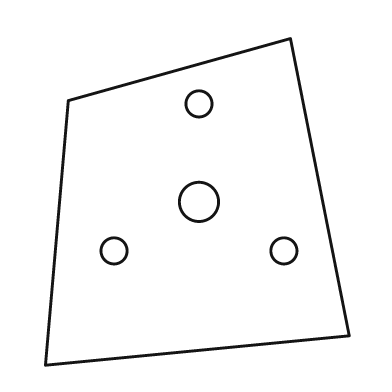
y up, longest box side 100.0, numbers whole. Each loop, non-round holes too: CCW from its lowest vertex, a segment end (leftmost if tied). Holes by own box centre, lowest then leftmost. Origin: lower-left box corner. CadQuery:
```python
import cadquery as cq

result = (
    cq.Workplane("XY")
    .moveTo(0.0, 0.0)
    .lineTo(93.0, 9.0)
    .lineTo(75.0, 100.0)
    .lineTo(7.0, 81.0)
    .close()
    .moveTo(21.0, 35.0)
    .circle(4.0)
    .moveTo(73.0, 35.0)
    .circle(4.0)
    .moveTo(47.0, 50.0)
    .circle(6.0)
    .moveTo(47.0, 80.0)
    .circle(4.0)
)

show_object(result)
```